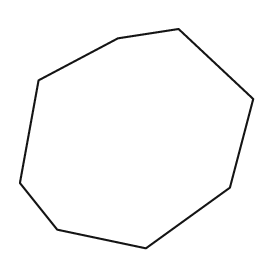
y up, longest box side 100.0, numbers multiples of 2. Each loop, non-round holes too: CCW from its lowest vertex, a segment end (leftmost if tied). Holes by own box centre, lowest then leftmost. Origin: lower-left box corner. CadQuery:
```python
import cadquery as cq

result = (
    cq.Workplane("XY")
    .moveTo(54.0, 0.0)
    .lineTo(90.0, 26.0)
    .lineTo(100.0, 64.0)
    .lineTo(68.0, 94.0)
    .lineTo(42.0, 90.0)
    .lineTo(8.0, 72.0)
    .lineTo(0.0, 28.0)
    .lineTo(16.0, 8.0)
    .close()
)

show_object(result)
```